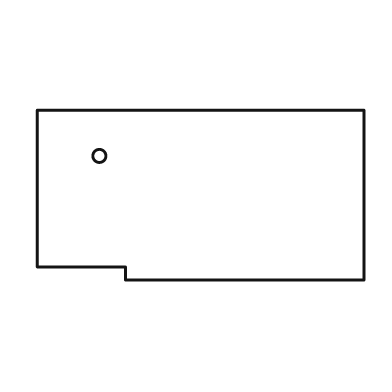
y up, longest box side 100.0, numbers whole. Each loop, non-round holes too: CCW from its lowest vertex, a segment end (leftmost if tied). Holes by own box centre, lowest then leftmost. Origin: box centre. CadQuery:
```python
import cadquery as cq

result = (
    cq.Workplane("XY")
    .moveTo(-23.0, -26.0)
    .lineTo(50.0, -26.0)
    .lineTo(50.0, 26.0)
    .lineTo(-50.0, 26.0)
    .lineTo(-50.0, -22.0)
    .lineTo(-23.0, -22.0)
    .close()
    .moveTo(-31.0, 12.0)
    .circle(2.0)
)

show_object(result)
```